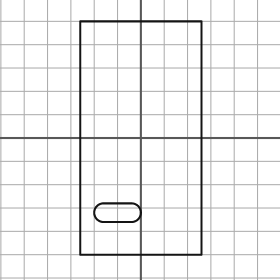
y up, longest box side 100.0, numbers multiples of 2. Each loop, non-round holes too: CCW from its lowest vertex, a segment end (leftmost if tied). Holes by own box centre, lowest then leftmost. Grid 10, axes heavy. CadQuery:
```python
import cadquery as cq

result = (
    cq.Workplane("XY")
    .moveTo(-26.0, -50.0)
    .lineTo(26.0, -50.0)
    .lineTo(26.0, 50.0)
    .lineTo(-26.0, 50.0)
    .close()
    .moveTo(-16.0, -36.0)
    .lineTo(-4.0, -36.0)
    .threePointArc((0.0, -32.0), (-4.0, -28.0))
    .lineTo(-16.0, -28.0)
    .threePointArc((-20.0, -32.0), (-16.0, -36.0))
    .close()
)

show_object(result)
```